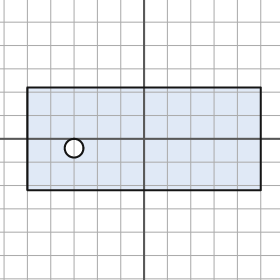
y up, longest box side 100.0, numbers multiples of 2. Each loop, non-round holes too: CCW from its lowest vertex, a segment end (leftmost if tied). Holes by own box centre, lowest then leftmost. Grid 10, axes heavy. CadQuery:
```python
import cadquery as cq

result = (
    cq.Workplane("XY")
    .moveTo(-50.0, -22.0)
    .lineTo(50.0, -22.0)
    .lineTo(50.0, 22.0)
    .lineTo(-50.0, 22.0)
    .close()
    .moveTo(-30.0, -4.0)
    .circle(4.0)
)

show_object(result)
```